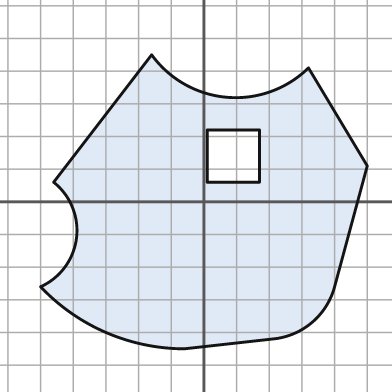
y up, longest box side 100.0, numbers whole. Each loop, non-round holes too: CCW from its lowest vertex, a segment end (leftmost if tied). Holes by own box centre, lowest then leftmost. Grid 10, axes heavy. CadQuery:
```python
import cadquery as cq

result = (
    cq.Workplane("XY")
    .moveTo(-6.0, -45.0)
    .lineTo(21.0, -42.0)
    .threePointArc((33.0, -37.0), (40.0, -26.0))
    .lineTo(50.0, 11.0)
    .lineTo(32.0, 41.0)
    .threePointArc((7.0, 32.0), (-16.0, 45.0))
    .lineTo(-46.0, 6.0)
    .threePointArc((-39.0, -11.0), (-50.0, -26.0))
    .threePointArc((-30.0, -40.0), (-6.0, -45.0))
    .close()
    .moveTo(1.0, 6.0)
    .lineTo(17.0, 6.0)
    .lineTo(17.0, 22.0)
    .lineTo(1.0, 22.0)
    .close()
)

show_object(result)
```